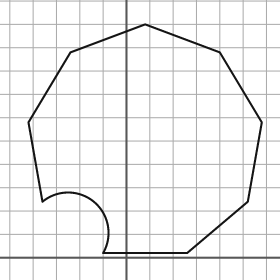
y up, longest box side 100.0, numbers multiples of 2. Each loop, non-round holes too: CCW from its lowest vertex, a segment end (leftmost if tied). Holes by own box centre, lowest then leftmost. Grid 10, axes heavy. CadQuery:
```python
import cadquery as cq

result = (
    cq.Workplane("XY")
    .moveTo(-10.0, 2.0)
    .lineTo(26.0, 2.0)
    .lineTo(52.0, 24.0)
    .lineTo(58.0, 58.0)
    .lineTo(40.0, 88.0)
    .lineTo(8.0, 100.0)
    .lineTo(-24.0, 88.0)
    .lineTo(-42.0, 58.0)
    .lineTo(-36.0, 24.0)
    .threePointArc((-14.0, 24.0), (-10.0, 2.0))
    .close()
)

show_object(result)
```